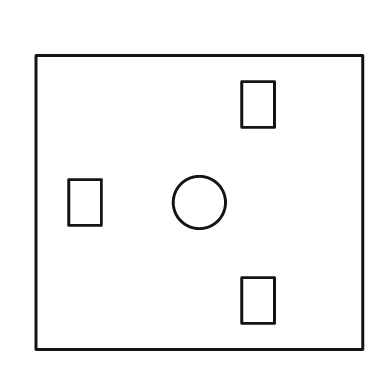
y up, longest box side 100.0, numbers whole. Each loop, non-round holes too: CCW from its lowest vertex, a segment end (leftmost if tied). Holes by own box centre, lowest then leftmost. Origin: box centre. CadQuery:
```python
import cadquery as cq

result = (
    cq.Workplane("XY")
    .moveTo(-50.0, -45.0)
    .lineTo(50.0, -45.0)
    .lineTo(50.0, 45.0)
    .lineTo(-50.0, 45.0)
    .close()
    .moveTo(13.0, -37.0)
    .lineTo(23.0, -37.0)
    .lineTo(23.0, -23.0)
    .lineTo(13.0, -23.0)
    .close()
    .moveTo(-40.0, -7.0)
    .lineTo(-30.0, -7.0)
    .lineTo(-30.0, 7.0)
    .lineTo(-40.0, 7.0)
    .close()
    .moveTo(0.0, 0.0)
    .circle(8.0)
    .moveTo(13.0, 23.0)
    .lineTo(23.0, 23.0)
    .lineTo(23.0, 37.0)
    .lineTo(13.0, 37.0)
    .close()
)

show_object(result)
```